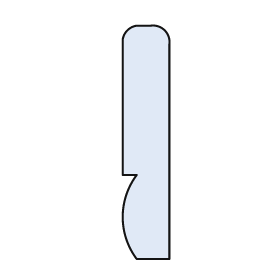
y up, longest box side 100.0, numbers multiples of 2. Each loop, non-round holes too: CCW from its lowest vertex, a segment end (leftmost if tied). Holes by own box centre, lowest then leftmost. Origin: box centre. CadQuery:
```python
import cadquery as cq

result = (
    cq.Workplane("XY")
    .moveTo(-4.0, -50.0)
    .lineTo(10.0, -50.0)
    .lineTo(10.0, 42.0)
    .threePointArc((8.0, 48.0), (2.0, 50.0))
    .lineTo(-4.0, 50.0)
    .threePointArc((-8.0, 48.0), (-10.0, 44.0))
    .lineTo(-10.0, -14.0)
    .lineTo(-4.0, -14.0)
    .threePointArc((-10.0, -32.0), (-4.0, -50.0))
    .close()
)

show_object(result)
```